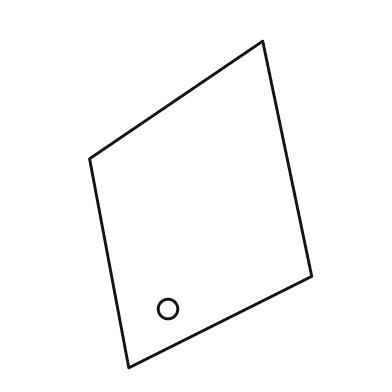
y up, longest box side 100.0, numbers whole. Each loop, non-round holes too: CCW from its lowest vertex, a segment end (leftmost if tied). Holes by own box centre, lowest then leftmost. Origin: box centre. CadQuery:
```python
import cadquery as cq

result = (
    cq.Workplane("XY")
    .moveTo(-22.0, -50.0)
    .lineTo(34.0, -22.0)
    .lineTo(19.0, 50.0)
    .lineTo(-34.0, 14.0)
    .close()
    .moveTo(-10.0, -32.0)
    .circle(3.0)
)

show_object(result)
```